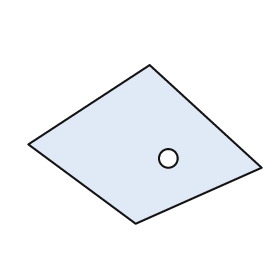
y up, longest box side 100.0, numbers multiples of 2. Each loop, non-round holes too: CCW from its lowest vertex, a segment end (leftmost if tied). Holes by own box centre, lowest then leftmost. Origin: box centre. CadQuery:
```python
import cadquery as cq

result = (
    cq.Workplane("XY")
    .moveTo(-4.0, -34.0)
    .lineTo(50.0, -10.0)
    .lineTo(2.0, 34.0)
    .lineTo(-50.0, 0.0)
    .close()
    .moveTo(10.0, -6.0)
    .circle(4.0)
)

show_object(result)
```